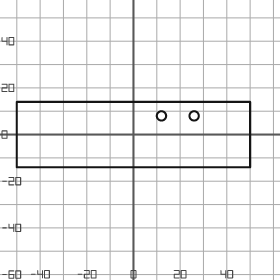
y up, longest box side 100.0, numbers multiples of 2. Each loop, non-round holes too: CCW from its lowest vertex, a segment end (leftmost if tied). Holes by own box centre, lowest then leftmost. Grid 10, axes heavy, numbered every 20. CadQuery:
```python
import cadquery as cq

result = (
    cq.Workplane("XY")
    .moveTo(-50.0, -14.0)
    .lineTo(50.0, -14.0)
    .lineTo(50.0, 14.0)
    .lineTo(-50.0, 14.0)
    .close()
    .moveTo(12.0, 8.0)
    .circle(2.0)
    .moveTo(26.0, 8.0)
    .circle(2.0)
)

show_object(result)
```